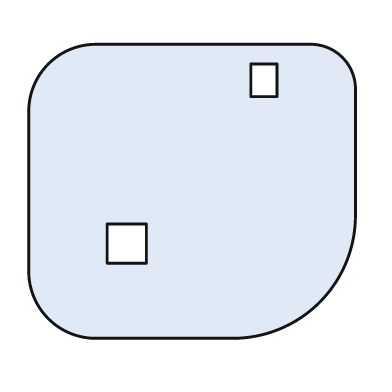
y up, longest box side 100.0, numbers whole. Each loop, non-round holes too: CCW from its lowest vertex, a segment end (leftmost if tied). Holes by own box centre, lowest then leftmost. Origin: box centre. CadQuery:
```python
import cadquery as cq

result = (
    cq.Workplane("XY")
    .moveTo(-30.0, -45.0)
    .lineTo(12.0, -45.0)
    .threePointArc((39.0, -34.0), (50.0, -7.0))
    .lineTo(50.0, 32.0)
    .threePointArc((46.0, 41.0), (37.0, 45.0))
    .lineTo(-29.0, 45.0)
    .threePointArc((-44.0, 39.0), (-50.0, 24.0))
    .lineTo(-50.0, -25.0)
    .threePointArc((-44.0, -39.0), (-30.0, -45.0))
    .close()
    .moveTo(-26.0, -22.0)
    .lineTo(-14.0, -22.0)
    .lineTo(-14.0, -10.0)
    .lineTo(-26.0, -10.0)
    .close()
    .moveTo(18.0, 29.0)
    .lineTo(26.0, 29.0)
    .lineTo(26.0, 39.0)
    .lineTo(18.0, 39.0)
    .close()
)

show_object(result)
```